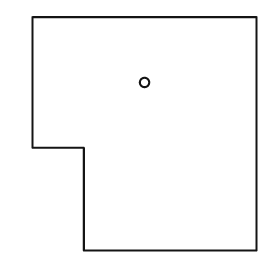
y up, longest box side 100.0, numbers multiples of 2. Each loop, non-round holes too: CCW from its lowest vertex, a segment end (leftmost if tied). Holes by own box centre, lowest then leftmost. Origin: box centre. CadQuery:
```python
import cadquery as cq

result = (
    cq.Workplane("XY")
    .moveTo(-26.0, -50.0)
    .lineTo(48.0, -50.0)
    .lineTo(48.0, 50.0)
    .lineTo(-48.0, 50.0)
    .lineTo(-48.0, -6.0)
    .lineTo(-26.0, -6.0)
    .close()
    .moveTo(0.0, 22.0)
    .circle(2.0)
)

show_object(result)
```